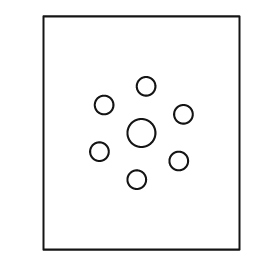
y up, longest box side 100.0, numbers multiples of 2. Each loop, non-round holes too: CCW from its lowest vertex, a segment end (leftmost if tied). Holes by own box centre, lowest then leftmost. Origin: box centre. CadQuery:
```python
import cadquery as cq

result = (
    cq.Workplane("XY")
    .moveTo(-42.0, -50.0)
    .lineTo(42.0, -50.0)
    .lineTo(42.0, 50.0)
    .lineTo(-42.0, 50.0)
    .close()
    .moveTo(-2.0, -20.0)
    .circle(4.0)
    .moveTo(16.0, -12.0)
    .circle(4.0)
    .moveTo(-18.0, -8.0)
    .circle(4.0)
    .moveTo(0.0, 0.0)
    .circle(6.0)
    .moveTo(18.0, 8.0)
    .circle(4.0)
    .moveTo(-16.0, 12.0)
    .circle(4.0)
    .moveTo(2.0, 20.0)
    .circle(4.0)
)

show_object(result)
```